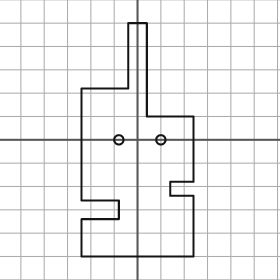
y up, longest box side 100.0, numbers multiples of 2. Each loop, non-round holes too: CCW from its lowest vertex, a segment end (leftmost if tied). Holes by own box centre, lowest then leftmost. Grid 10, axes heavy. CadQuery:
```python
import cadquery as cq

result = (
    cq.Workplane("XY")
    .moveTo(-24.0, -50.0)
    .lineTo(24.0, -50.0)
    .lineTo(24.0, -24.0)
    .lineTo(14.0, -24.0)
    .lineTo(14.0, -18.0)
    .lineTo(24.0, -18.0)
    .lineTo(24.0, 10.0)
    .lineTo(4.0, 10.0)
    .lineTo(4.0, 50.0)
    .lineTo(-4.0, 50.0)
    .lineTo(-4.0, 22.0)
    .lineTo(-24.0, 22.0)
    .lineTo(-24.0, -26.0)
    .lineTo(-8.0, -26.0)
    .lineTo(-8.0, -34.0)
    .lineTo(-24.0, -34.0)
    .close()
    .moveTo(-8.0, 0.0)
    .circle(2.0)
    .moveTo(10.0, 0.0)
    .circle(2.0)
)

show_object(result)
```